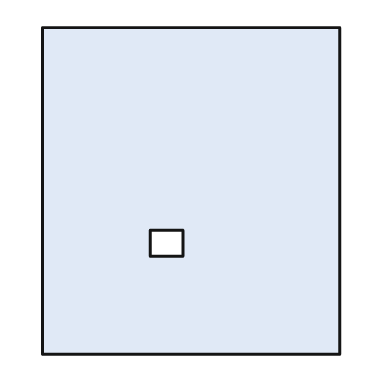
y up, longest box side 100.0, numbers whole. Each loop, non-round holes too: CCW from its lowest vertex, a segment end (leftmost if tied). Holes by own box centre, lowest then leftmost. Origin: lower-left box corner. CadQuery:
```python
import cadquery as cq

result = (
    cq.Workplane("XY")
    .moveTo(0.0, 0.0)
    .lineTo(91.0, 0.0)
    .lineTo(91.0, 100.0)
    .lineTo(0.0, 100.0)
    .close()
    .moveTo(33.0, 30.0)
    .lineTo(43.0, 30.0)
    .lineTo(43.0, 38.0)
    .lineTo(33.0, 38.0)
    .close()
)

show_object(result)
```